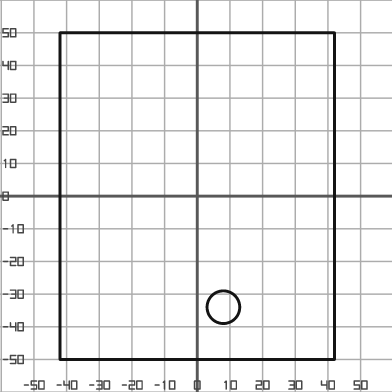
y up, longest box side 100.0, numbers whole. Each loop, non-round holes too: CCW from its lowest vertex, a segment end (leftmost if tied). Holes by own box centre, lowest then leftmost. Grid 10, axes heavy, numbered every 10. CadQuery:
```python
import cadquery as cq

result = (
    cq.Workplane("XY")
    .moveTo(-42.0, -50.0)
    .lineTo(42.0, -50.0)
    .lineTo(42.0, 50.0)
    .lineTo(-42.0, 50.0)
    .close()
    .moveTo(8.0, -34.0)
    .circle(5.0)
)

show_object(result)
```